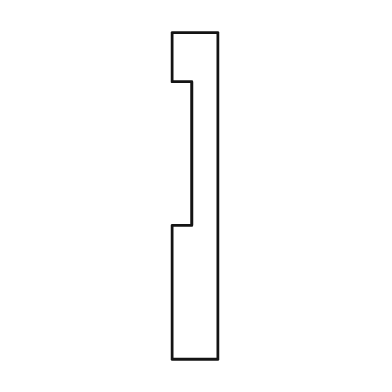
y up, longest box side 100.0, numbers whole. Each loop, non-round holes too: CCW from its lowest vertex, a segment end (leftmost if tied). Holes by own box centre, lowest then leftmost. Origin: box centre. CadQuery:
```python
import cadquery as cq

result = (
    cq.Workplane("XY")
    .moveTo(-7.0, -50.0)
    .lineTo(7.0, -50.0)
    .lineTo(7.0, 50.0)
    .lineTo(-7.0, 50.0)
    .lineTo(-7.0, 35.0)
    .lineTo(-1.0, 35.0)
    .lineTo(-1.0, -9.0)
    .lineTo(-7.0, -9.0)
    .close()
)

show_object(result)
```